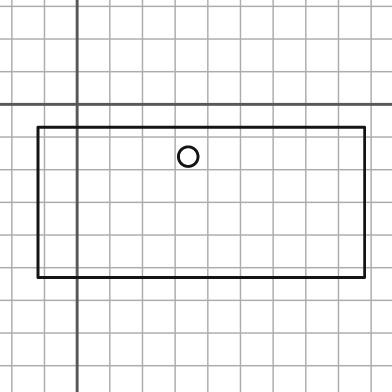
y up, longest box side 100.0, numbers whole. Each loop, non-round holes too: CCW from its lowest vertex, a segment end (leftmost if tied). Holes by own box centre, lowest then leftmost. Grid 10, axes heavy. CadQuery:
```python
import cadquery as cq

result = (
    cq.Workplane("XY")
    .moveTo(-12.0, -53.0)
    .lineTo(88.0, -53.0)
    .lineTo(88.0, -7.0)
    .lineTo(-12.0, -7.0)
    .close()
    .moveTo(34.0, -16.0)
    .circle(3.0)
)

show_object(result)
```